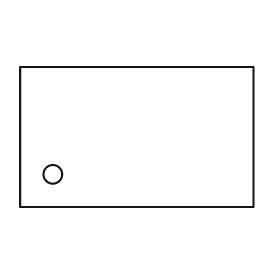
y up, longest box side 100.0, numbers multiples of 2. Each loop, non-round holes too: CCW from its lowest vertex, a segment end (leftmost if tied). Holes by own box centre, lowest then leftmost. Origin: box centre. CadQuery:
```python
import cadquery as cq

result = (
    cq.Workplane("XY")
    .moveTo(-50.0, -30.0)
    .lineTo(50.0, -30.0)
    .lineTo(50.0, 30.0)
    .lineTo(-50.0, 30.0)
    .close()
    .moveTo(-36.0, -16.0)
    .circle(4.0)
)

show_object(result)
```